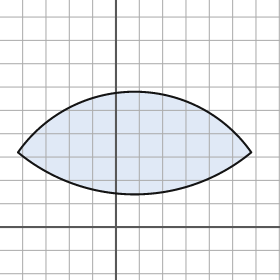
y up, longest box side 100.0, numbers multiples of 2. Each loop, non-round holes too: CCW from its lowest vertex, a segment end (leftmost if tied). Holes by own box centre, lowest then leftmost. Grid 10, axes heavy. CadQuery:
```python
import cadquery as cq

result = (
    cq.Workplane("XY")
    .moveTo(-42.0, 32.0)
    .threePointArc((8.0, 14.0), (58.0, 32.0))
    .threePointArc((8.0, 58.0), (-42.0, 32.0))
    .close()
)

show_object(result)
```